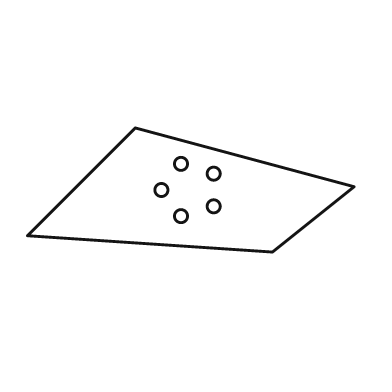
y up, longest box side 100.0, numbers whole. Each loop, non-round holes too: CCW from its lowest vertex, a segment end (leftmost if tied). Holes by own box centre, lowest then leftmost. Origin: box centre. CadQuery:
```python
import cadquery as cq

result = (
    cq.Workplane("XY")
    .moveTo(25.0, -19.0)
    .lineTo(50.0, 1.0)
    .lineTo(-17.0, 19.0)
    .lineTo(-50.0, -14.0)
    .close()
    .moveTo(-3.0, -8.0)
    .circle(2.0)
    .moveTo(7.0, -5.0)
    .circle(2.0)
    .moveTo(-9.0, 0.0)
    .circle(2.0)
    .moveTo(7.0, 5.0)
    .circle(2.0)
    .moveTo(-3.0, 8.0)
    .circle(2.0)
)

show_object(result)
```